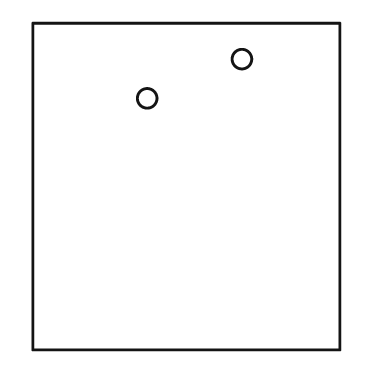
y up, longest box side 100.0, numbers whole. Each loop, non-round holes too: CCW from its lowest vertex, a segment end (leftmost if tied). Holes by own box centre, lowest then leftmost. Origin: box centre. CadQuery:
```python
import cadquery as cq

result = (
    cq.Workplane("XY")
    .moveTo(-47.0, -50.0)
    .lineTo(47.0, -50.0)
    .lineTo(47.0, 50.0)
    .lineTo(-47.0, 50.0)
    .close()
    .moveTo(-12.0, 27.0)
    .circle(3.0)
    .moveTo(17.0, 39.0)
    .circle(3.0)
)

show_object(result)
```